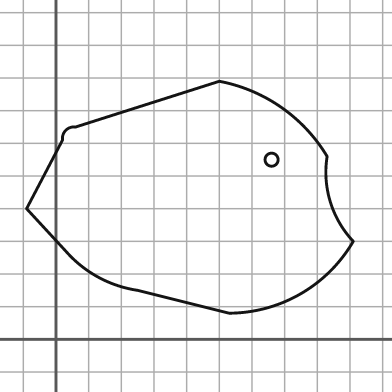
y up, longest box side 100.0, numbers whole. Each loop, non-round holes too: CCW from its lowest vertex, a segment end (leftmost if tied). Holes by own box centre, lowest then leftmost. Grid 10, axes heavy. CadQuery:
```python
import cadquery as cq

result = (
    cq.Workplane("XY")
    .moveTo(53.0, 8.0)
    .threePointArc((75.0, 14.0), (91.0, 30.0))
    .threePointArc((84.0, 42.0), (83.0, 56.0))
    .threePointArc((69.0, 71.0), (50.0, 79.0))
    .lineTo(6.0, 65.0)
    .threePointArc((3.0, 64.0), (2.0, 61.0))
    .lineTo(-9.0, 40.0)
    .lineTo(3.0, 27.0)
    .threePointArc((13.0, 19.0), (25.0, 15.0))
    .close()
    .moveTo(66.0, 55.0)
    .circle(2.0)
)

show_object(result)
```